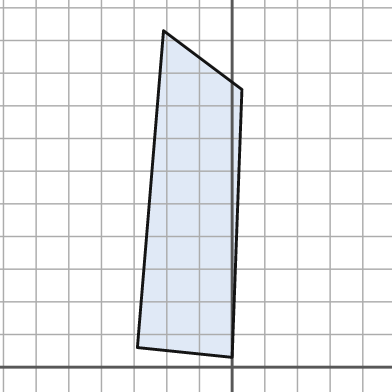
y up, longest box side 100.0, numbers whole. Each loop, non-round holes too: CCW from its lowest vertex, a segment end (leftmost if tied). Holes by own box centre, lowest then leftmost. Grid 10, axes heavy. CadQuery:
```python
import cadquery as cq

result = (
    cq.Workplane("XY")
    .moveTo(0.0, 3.0)
    .lineTo(3.0, 85.0)
    .lineTo(-21.0, 103.0)
    .lineTo(-29.0, 6.0)
    .close()
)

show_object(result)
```